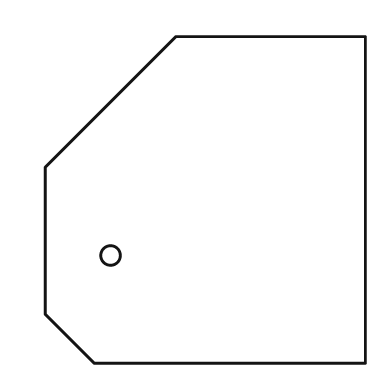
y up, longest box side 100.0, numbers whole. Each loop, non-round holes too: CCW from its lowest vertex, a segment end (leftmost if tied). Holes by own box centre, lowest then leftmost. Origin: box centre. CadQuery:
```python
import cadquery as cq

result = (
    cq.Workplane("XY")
    .moveTo(-34.0, -50.0)
    .lineTo(49.0, -50.0)
    .lineTo(49.0, 50.0)
    .lineTo(-9.0, 50.0)
    .lineTo(-49.0, 10.0)
    .lineTo(-49.0, -35.0)
    .close()
    .moveTo(-29.0, -17.0)
    .circle(3.0)
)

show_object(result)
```